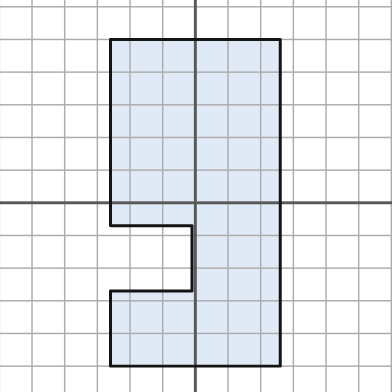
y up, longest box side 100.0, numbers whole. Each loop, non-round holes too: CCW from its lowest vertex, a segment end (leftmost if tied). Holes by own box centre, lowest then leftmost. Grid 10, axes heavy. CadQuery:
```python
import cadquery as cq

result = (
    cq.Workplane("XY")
    .moveTo(-26.0, -50.0)
    .lineTo(26.0, -50.0)
    .lineTo(26.0, 50.0)
    .lineTo(-26.0, 50.0)
    .lineTo(-26.0, -7.0)
    .lineTo(-1.0, -7.0)
    .lineTo(-1.0, -27.0)
    .lineTo(-26.0, -27.0)
    .close()
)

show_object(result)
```